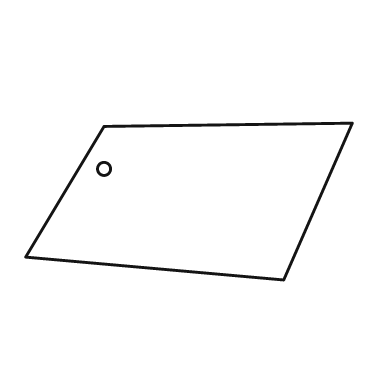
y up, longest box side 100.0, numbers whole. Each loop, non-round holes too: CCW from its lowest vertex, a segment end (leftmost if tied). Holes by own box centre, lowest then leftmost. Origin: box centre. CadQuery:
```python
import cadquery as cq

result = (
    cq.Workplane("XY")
    .moveTo(29.0, -24.0)
    .lineTo(50.0, 24.0)
    .lineTo(-26.0, 23.0)
    .lineTo(-50.0, -17.0)
    .close()
    .moveTo(-26.0, 10.0)
    .circle(2.0)
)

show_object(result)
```